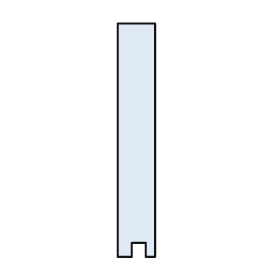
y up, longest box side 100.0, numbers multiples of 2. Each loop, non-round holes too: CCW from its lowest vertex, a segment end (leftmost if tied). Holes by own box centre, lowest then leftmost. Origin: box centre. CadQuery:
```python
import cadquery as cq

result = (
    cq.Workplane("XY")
    .moveTo(-8.0, -50.0)
    .lineTo(-2.0, -50.0)
    .lineTo(-2.0, -44.0)
    .lineTo(4.0, -44.0)
    .lineTo(4.0, -50.0)
    .lineTo(8.0, -50.0)
    .lineTo(8.0, 50.0)
    .lineTo(-8.0, 50.0)
    .close()
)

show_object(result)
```